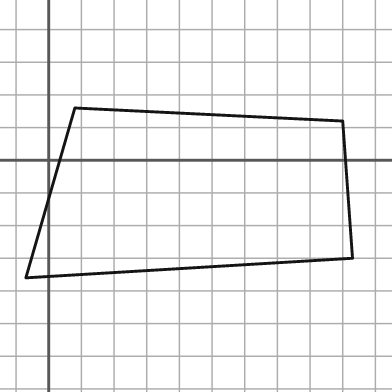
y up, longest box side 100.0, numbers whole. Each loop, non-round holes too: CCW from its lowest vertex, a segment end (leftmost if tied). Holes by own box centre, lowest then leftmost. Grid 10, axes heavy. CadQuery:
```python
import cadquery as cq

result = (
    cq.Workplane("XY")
    .moveTo(-7.0, -36.0)
    .lineTo(93.0, -30.0)
    .lineTo(90.0, 12.0)
    .lineTo(8.0, 16.0)
    .close()
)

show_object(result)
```